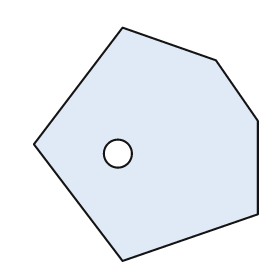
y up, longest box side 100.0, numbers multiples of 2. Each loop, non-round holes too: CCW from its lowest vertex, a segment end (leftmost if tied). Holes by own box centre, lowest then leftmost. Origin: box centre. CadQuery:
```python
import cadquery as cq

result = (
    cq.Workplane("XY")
    .moveTo(-10.0, -50.0)
    .lineTo(48.0, -30.0)
    .lineTo(48.0, 10.0)
    .lineTo(30.0, 36.0)
    .lineTo(-10.0, 50.0)
    .lineTo(-48.0, 0.0)
    .close()
    .moveTo(-12.0, -4.0)
    .circle(6.0)
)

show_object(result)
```